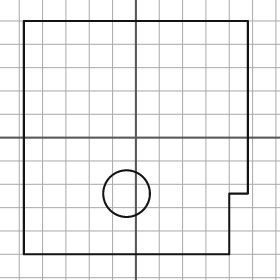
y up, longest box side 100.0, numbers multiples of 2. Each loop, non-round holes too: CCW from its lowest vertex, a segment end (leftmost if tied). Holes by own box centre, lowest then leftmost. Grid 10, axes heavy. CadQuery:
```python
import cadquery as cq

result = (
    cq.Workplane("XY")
    .moveTo(-48.0, -50.0)
    .lineTo(40.0, -50.0)
    .lineTo(40.0, -24.0)
    .lineTo(48.0, -24.0)
    .lineTo(48.0, 50.0)
    .lineTo(-48.0, 50.0)
    .close()
    .moveTo(-4.0, -24.0)
    .circle(10.0)
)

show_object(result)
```